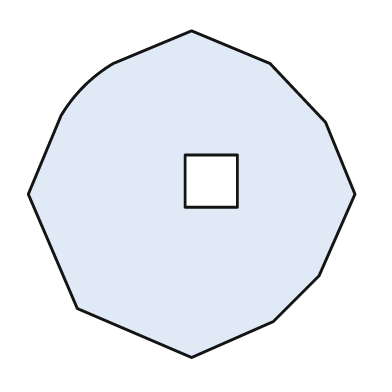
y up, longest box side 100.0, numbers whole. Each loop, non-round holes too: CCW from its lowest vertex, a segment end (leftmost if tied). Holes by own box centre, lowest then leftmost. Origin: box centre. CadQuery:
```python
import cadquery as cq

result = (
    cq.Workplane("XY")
    .moveTo(0.0, -50.0)
    .lineTo(25.0, -39.0)
    .lineTo(39.0, -25.0)
    .lineTo(50.0, 0.0)
    .lineTo(41.0, 22.0)
    .lineTo(24.0, 40.0)
    .lineTo(0.0, 50.0)
    .lineTo(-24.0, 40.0)
    .threePointArc((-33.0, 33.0), (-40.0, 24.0))
    .lineTo(-50.0, 0.0)
    .lineTo(-35.0, -35.0)
    .close()
    .moveTo(-2.0, -4.0)
    .lineTo(14.0, -4.0)
    .lineTo(14.0, 12.0)
    .lineTo(-2.0, 12.0)
    .close()
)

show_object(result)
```